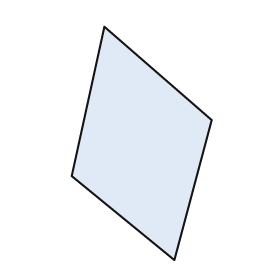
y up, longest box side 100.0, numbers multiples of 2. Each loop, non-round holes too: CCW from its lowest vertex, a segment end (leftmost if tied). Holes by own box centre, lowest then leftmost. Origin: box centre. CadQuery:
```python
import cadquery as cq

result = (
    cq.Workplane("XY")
    .moveTo(14.0, -50.0)
    .lineTo(30.0, 10.0)
    .lineTo(-16.0, 50.0)
    .lineTo(-30.0, -14.0)
    .close()
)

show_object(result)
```